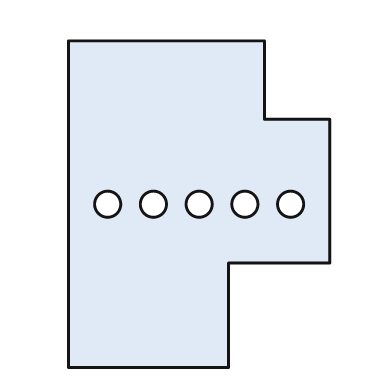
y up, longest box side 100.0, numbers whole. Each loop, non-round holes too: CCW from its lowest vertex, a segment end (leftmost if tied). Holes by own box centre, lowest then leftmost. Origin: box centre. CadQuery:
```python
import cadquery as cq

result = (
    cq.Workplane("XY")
    .moveTo(-40.0, -50.0)
    .lineTo(9.0, -50.0)
    .lineTo(9.0, -18.0)
    .lineTo(40.0, -18.0)
    .lineTo(40.0, 26.0)
    .lineTo(20.0, 26.0)
    .lineTo(20.0, 50.0)
    .lineTo(-40.0, 50.0)
    .close()
    .moveTo(-28.0, 0.0)
    .circle(4.0)
    .moveTo(-14.0, 0.0)
    .circle(4.0)
    .moveTo(0.0, 0.0)
    .circle(4.0)
    .moveTo(14.0, 0.0)
    .circle(4.0)
    .moveTo(28.0, 0.0)
    .circle(4.0)
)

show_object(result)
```